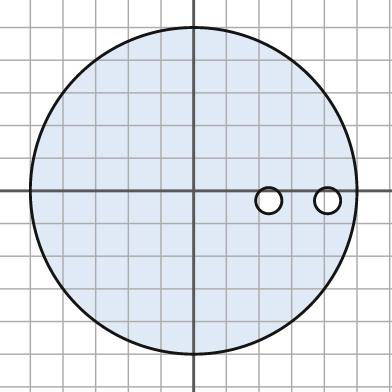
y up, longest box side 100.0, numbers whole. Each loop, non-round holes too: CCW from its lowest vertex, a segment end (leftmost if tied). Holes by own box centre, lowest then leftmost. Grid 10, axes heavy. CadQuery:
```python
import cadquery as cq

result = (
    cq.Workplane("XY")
    .moveTo(0.0, 0.0)
    .circle(50.0)
    .moveTo(23.0, -3.0)
    .circle(4.0)
    .moveTo(41.0, -3.0)
    .circle(4.0)
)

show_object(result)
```